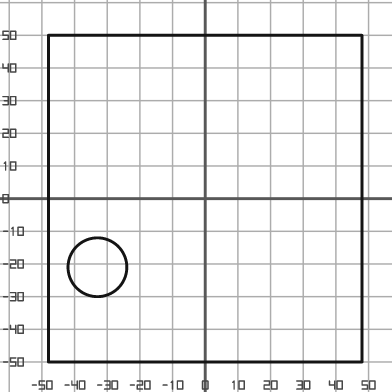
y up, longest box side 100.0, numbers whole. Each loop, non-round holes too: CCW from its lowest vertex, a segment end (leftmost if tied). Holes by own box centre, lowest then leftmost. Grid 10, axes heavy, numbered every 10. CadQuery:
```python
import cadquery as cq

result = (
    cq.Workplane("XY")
    .moveTo(-48.0, -50.0)
    .lineTo(48.0, -50.0)
    .lineTo(48.0, 50.0)
    .lineTo(-48.0, 50.0)
    .close()
    .moveTo(-33.0, -21.0)
    .circle(9.0)
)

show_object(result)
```